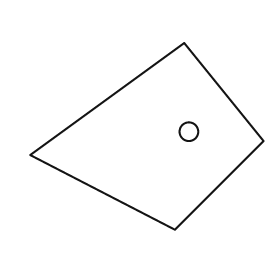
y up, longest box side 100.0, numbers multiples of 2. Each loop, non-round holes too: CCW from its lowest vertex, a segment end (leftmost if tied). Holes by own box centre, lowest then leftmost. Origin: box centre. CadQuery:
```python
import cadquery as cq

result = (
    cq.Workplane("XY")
    .moveTo(12.0, -40.0)
    .lineTo(50.0, -2.0)
    .lineTo(16.0, 40.0)
    .lineTo(-50.0, -8.0)
    .close()
    .moveTo(18.0, 2.0)
    .circle(4.0)
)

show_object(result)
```